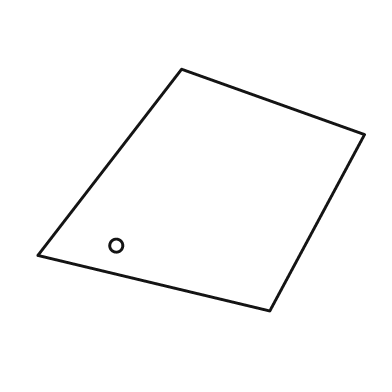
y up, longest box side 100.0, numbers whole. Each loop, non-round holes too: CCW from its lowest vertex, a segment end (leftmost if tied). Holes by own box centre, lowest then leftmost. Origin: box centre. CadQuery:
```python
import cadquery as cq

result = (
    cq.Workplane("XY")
    .moveTo(21.0, -37.0)
    .lineTo(50.0, 17.0)
    .lineTo(-6.0, 37.0)
    .lineTo(-50.0, -20.0)
    .close()
    .moveTo(-26.0, -17.0)
    .circle(2.0)
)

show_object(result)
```